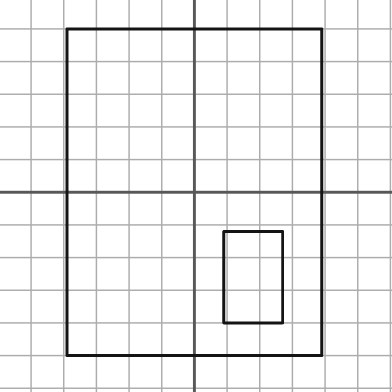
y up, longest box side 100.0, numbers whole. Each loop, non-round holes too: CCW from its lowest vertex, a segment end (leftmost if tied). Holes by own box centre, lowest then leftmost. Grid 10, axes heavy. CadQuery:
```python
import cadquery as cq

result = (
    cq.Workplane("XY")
    .moveTo(-39.0, -50.0)
    .lineTo(39.0, -50.0)
    .lineTo(39.0, 50.0)
    .lineTo(-39.0, 50.0)
    .close()
    .moveTo(9.0, -40.0)
    .lineTo(27.0, -40.0)
    .lineTo(27.0, -12.0)
    .lineTo(9.0, -12.0)
    .close()
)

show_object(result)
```